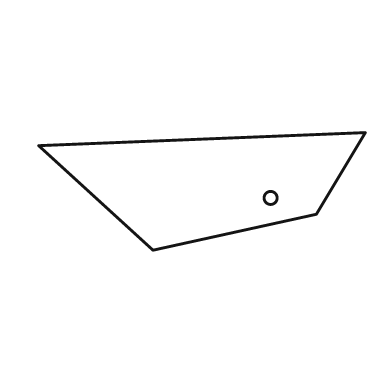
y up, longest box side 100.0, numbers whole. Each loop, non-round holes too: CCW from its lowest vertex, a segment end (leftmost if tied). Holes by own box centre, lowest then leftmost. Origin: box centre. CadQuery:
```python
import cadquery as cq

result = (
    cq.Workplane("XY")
    .moveTo(-15.0, -18.0)
    .lineTo(35.0, -7.0)
    .lineTo(50.0, 18.0)
    .lineTo(-50.0, 14.0)
    .close()
    .moveTo(21.0, -2.0)
    .circle(2.0)
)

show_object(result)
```